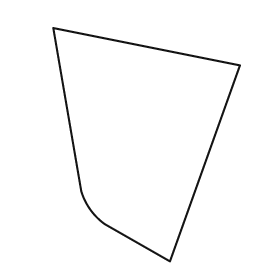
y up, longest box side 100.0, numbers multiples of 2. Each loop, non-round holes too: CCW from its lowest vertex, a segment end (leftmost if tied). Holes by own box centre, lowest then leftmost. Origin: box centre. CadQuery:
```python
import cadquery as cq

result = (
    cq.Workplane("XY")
    .moveTo(10.0, -50.0)
    .lineTo(40.0, 34.0)
    .lineTo(-40.0, 50.0)
    .lineTo(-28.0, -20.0)
    .threePointArc((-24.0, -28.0), (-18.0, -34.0))
    .close()
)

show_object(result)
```